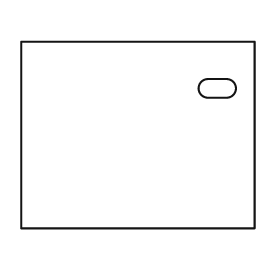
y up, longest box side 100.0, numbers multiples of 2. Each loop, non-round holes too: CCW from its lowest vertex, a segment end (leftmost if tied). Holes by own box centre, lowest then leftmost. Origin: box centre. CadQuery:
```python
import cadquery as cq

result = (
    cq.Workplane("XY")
    .moveTo(-50.0, -40.0)
    .lineTo(50.0, -40.0)
    .lineTo(50.0, 40.0)
    .lineTo(-50.0, 40.0)
    .close()
    .moveTo(30.0, 16.0)
    .lineTo(38.0, 16.0)
    .threePointArc((42.0, 20.0), (38.0, 24.0))
    .lineTo(30.0, 24.0)
    .threePointArc((26.0, 20.0), (30.0, 16.0))
    .close()
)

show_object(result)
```